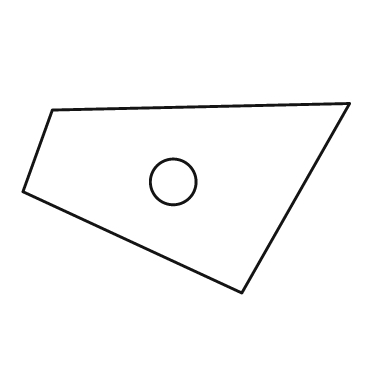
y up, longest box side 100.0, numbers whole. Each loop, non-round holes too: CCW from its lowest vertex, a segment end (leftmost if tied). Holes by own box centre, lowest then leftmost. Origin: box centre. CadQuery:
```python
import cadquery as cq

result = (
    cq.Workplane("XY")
    .moveTo(17.0, -29.0)
    .lineTo(50.0, 29.0)
    .lineTo(-41.0, 27.0)
    .lineTo(-50.0, 2.0)
    .close()
    .moveTo(-4.0, 5.0)
    .circle(7.0)
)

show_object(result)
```